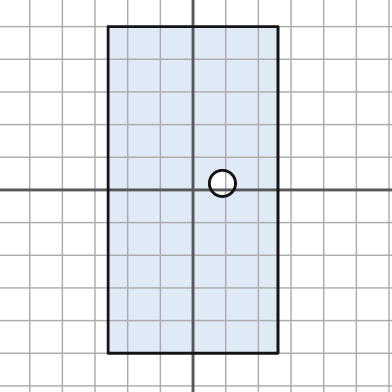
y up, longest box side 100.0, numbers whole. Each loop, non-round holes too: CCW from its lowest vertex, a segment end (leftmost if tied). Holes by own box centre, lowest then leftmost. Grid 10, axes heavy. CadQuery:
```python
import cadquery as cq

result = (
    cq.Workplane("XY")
    .moveTo(-26.0, -50.0)
    .lineTo(26.0, -50.0)
    .lineTo(26.0, 50.0)
    .lineTo(-26.0, 50.0)
    .close()
    .moveTo(9.0, 2.0)
    .circle(4.0)
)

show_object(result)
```